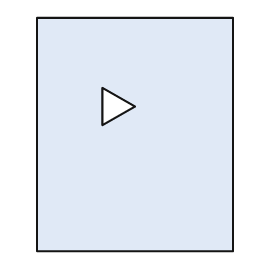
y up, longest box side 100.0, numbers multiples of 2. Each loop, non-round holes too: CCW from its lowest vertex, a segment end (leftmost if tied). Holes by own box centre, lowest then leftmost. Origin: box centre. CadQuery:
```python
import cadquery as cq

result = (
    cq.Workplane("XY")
    .moveTo(-42.0, -50.0)
    .lineTo(42.0, -50.0)
    .lineTo(42.0, 50.0)
    .lineTo(-42.0, 50.0)
    .close()
    .moveTo(-14.0, 4.0)
    .lineTo(0.0, 12.0)
    .lineTo(-14.0, 20.0)
    .close()
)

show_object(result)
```